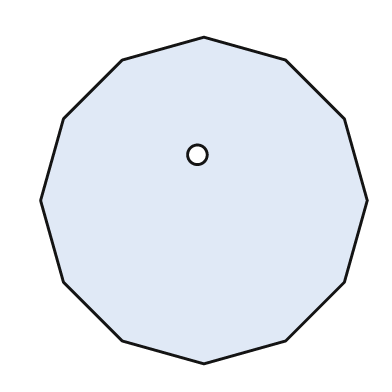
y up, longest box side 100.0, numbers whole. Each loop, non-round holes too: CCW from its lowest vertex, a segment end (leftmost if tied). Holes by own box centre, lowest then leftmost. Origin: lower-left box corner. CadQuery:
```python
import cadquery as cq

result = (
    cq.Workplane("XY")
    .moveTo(50.0, 0.0)
    .lineTo(75.0, 7.0)
    .lineTo(93.0, 25.0)
    .lineTo(100.0, 50.0)
    .lineTo(93.0, 75.0)
    .lineTo(75.0, 93.0)
    .lineTo(50.0, 100.0)
    .lineTo(25.0, 93.0)
    .lineTo(7.0, 75.0)
    .lineTo(0.0, 50.0)
    .lineTo(7.0, 25.0)
    .lineTo(25.0, 7.0)
    .close()
    .moveTo(48.0, 64.0)
    .circle(3.0)
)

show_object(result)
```